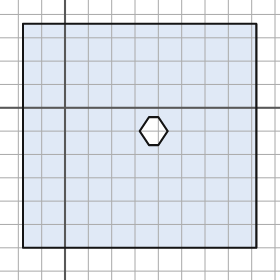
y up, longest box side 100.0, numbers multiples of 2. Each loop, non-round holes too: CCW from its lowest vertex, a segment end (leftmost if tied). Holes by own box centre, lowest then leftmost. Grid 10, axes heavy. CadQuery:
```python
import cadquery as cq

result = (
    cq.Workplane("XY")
    .moveTo(-18.0, -60.0)
    .lineTo(82.0, -60.0)
    .lineTo(82.0, 36.0)
    .lineTo(-18.0, 36.0)
    .close()
    .moveTo(36.0, -16.0)
    .lineTo(40.0, -16.0)
    .lineTo(44.0, -10.0)
    .lineTo(40.0, -4.0)
    .lineTo(36.0, -4.0)
    .lineTo(32.0, -10.0)
    .close()
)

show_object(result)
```